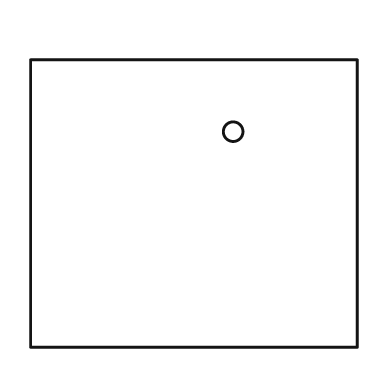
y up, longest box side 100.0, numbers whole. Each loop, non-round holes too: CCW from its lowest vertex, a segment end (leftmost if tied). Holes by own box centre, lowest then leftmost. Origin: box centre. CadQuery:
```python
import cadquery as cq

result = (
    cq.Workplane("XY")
    .moveTo(-50.0, -44.0)
    .lineTo(50.0, -44.0)
    .lineTo(50.0, 44.0)
    .lineTo(-50.0, 44.0)
    .close()
    .moveTo(12.0, 22.0)
    .circle(3.0)
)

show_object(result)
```